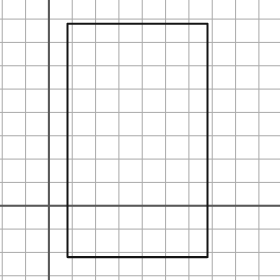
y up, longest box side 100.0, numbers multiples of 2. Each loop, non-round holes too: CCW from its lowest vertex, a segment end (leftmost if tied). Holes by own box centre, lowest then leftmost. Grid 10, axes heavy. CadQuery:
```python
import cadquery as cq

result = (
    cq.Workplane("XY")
    .moveTo(8.0, -22.0)
    .lineTo(68.0, -22.0)
    .lineTo(68.0, 78.0)
    .lineTo(8.0, 78.0)
    .close()
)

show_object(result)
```